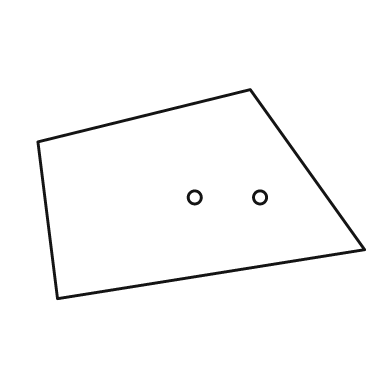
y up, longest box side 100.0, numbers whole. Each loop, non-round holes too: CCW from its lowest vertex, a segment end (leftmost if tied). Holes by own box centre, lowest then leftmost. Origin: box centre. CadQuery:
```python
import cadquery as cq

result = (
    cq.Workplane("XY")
    .moveTo(-44.0, -32.0)
    .lineTo(50.0, -17.0)
    .lineTo(15.0, 32.0)
    .lineTo(-50.0, 16.0)
    .close()
    .moveTo(-2.0, -1.0)
    .circle(2.0)
    .moveTo(18.0, -1.0)
    .circle(2.0)
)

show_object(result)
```